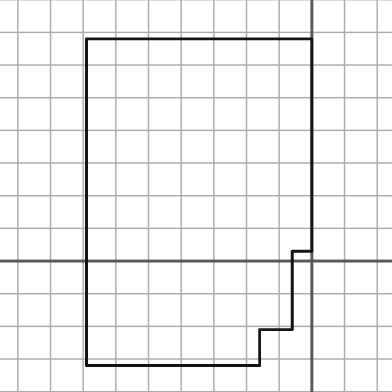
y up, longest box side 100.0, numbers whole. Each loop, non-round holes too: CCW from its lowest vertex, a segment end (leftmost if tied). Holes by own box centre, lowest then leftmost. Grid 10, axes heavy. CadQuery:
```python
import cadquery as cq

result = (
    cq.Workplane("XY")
    .moveTo(-69.0, -32.0)
    .lineTo(-16.0, -32.0)
    .lineTo(-16.0, -21.0)
    .lineTo(-6.0, -21.0)
    .lineTo(-6.0, 3.0)
    .lineTo(0.0, 3.0)
    .lineTo(0.0, 68.0)
    .lineTo(-69.0, 68.0)
    .close()
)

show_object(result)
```